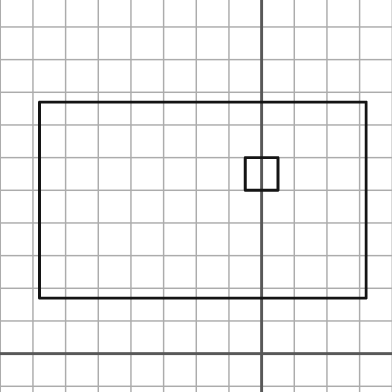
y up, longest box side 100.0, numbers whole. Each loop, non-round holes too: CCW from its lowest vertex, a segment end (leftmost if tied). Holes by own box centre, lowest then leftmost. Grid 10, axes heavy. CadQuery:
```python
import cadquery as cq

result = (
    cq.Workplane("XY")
    .moveTo(-68.0, 17.0)
    .lineTo(32.0, 17.0)
    .lineTo(32.0, 77.0)
    .lineTo(-68.0, 77.0)
    .close()
    .moveTo(-5.0, 50.0)
    .lineTo(5.0, 50.0)
    .lineTo(5.0, 60.0)
    .lineTo(-5.0, 60.0)
    .close()
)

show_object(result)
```